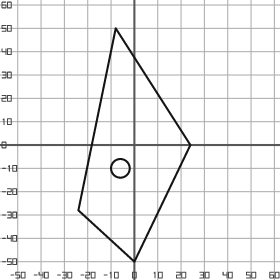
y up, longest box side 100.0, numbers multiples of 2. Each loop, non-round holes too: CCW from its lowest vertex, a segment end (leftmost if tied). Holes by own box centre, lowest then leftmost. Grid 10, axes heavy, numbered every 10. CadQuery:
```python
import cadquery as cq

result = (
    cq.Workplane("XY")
    .moveTo(0.0, -50.0)
    .lineTo(24.0, 0.0)
    .lineTo(-8.0, 50.0)
    .lineTo(-24.0, -28.0)
    .close()
    .moveTo(-6.0, -10.0)
    .circle(4.0)
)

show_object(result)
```